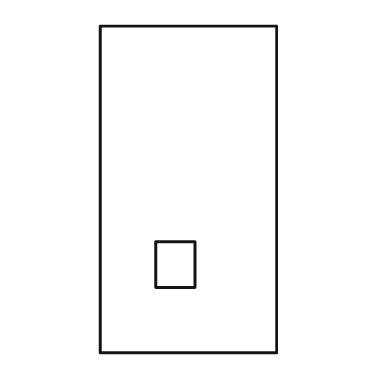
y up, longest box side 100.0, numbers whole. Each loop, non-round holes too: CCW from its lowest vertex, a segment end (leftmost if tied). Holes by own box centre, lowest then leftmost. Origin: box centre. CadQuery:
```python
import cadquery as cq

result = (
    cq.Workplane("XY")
    .moveTo(-27.0, -50.0)
    .lineTo(27.0, -50.0)
    .lineTo(27.0, 50.0)
    .lineTo(-27.0, 50.0)
    .close()
    .moveTo(-10.0, -30.0)
    .lineTo(2.0, -30.0)
    .lineTo(2.0, -16.0)
    .lineTo(-10.0, -16.0)
    .close()
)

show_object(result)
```